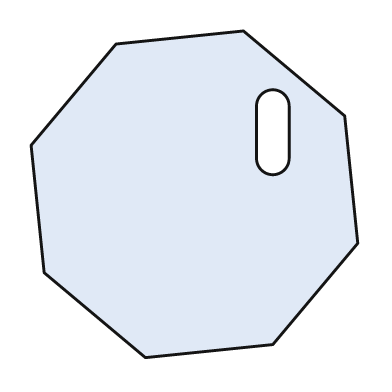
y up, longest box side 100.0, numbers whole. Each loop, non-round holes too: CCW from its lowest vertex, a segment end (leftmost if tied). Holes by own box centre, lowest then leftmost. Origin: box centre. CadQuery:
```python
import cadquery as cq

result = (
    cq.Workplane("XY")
    .moveTo(-15.0, -50.0)
    .lineTo(24.0, -46.0)
    .lineTo(50.0, -15.0)
    .lineTo(46.0, 24.0)
    .lineTo(15.0, 50.0)
    .lineTo(-24.0, 46.0)
    .lineTo(-50.0, 15.0)
    .lineTo(-46.0, -24.0)
    .close()
    .moveTo(19.0, 11.0)
    .threePointArc((24.0, 6.0), (29.0, 11.0))
    .lineTo(29.0, 27.0)
    .threePointArc((24.0, 32.0), (19.0, 27.0))
    .close()
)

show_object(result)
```